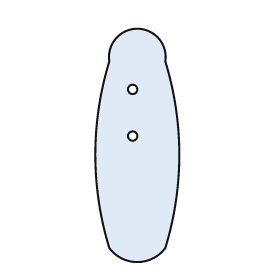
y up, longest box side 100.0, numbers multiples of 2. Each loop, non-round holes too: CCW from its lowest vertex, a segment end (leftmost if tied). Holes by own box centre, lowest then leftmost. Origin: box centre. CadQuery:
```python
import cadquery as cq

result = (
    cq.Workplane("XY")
    .moveTo(-12.0, -44.0)
    .threePointArc((0.0, -50.0), (12.0, -44.0))
    .threePointArc((18.0, -4.0), (12.0, 36.0))
    .threePointArc((0.0, 50.0), (-12.0, 36.0))
    .threePointArc((-18.0, -4.0), (-12.0, -44.0))
    .close()
    .moveTo(-2.0, 4.0)
    .circle(2.0)
    .moveTo(-2.0, 24.0)
    .circle(2.0)
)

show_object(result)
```